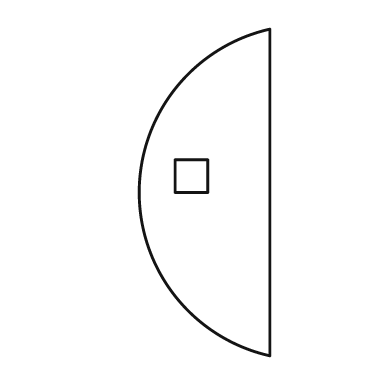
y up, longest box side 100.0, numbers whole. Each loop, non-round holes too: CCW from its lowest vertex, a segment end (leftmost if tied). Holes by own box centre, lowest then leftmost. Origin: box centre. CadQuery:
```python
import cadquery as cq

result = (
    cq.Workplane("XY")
    .moveTo(20.0, -50.0)
    .lineTo(20.0, 50.0)
    .threePointArc((-20.0, 0.0), (20.0, -50.0))
    .close()
    .moveTo(-9.0, 0.0)
    .lineTo(1.0, 0.0)
    .lineTo(1.0, 10.0)
    .lineTo(-9.0, 10.0)
    .close()
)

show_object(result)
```